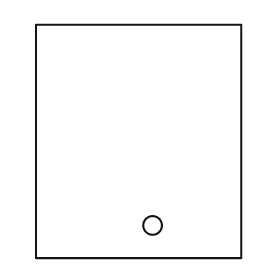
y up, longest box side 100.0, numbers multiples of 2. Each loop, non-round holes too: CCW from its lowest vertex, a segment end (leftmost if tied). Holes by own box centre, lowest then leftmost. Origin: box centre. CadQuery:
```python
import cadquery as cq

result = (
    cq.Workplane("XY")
    .moveTo(-44.0, -50.0)
    .lineTo(44.0, -50.0)
    .lineTo(44.0, 50.0)
    .lineTo(-44.0, 50.0)
    .close()
    .moveTo(6.0, -36.0)
    .circle(4.0)
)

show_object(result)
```